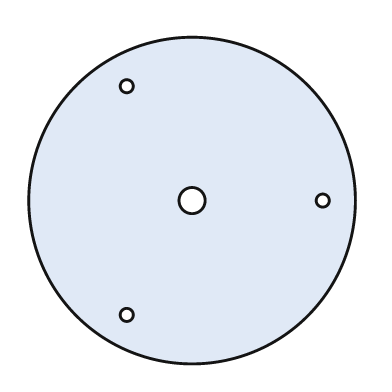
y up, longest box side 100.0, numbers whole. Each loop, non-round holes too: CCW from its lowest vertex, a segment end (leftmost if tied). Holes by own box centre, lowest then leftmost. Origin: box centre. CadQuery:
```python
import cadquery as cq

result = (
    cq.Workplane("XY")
    .moveTo(0.0, 0.0)
    .circle(50.0)
    .moveTo(-20.0, -35.0)
    .circle(2.0)
    .moveTo(0.0, 0.0)
    .circle(4.0)
    .moveTo(40.0, 0.0)
    .circle(2.0)
    .moveTo(-20.0, 35.0)
    .circle(2.0)
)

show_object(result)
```